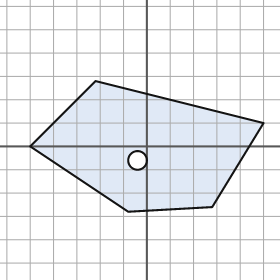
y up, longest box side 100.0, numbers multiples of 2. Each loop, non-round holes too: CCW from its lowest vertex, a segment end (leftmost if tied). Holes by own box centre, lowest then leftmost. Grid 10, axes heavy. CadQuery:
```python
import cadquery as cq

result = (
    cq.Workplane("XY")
    .moveTo(-8.0, -28.0)
    .lineTo(28.0, -26.0)
    .lineTo(50.0, 10.0)
    .lineTo(-22.0, 28.0)
    .lineTo(-50.0, 0.0)
    .close()
    .moveTo(-4.0, -6.0)
    .circle(4.0)
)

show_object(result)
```